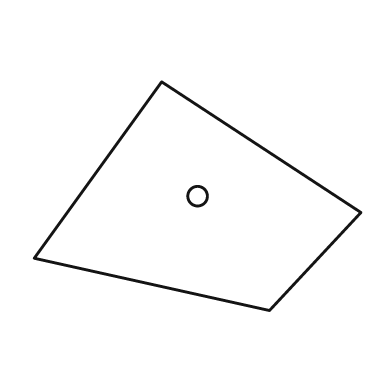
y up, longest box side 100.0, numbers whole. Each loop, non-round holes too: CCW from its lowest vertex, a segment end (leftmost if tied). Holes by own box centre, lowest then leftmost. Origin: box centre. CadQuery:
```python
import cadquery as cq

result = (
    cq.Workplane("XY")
    .moveTo(22.0, -35.0)
    .lineTo(50.0, -5.0)
    .lineTo(-11.0, 35.0)
    .lineTo(-50.0, -19.0)
    .close()
    .moveTo(0.0, 0.0)
    .circle(3.0)
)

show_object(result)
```